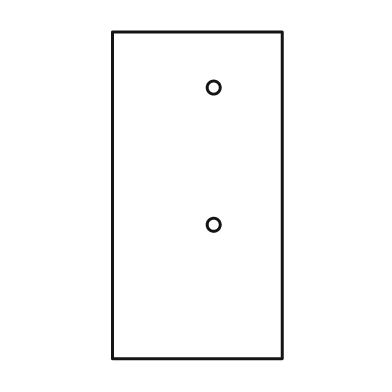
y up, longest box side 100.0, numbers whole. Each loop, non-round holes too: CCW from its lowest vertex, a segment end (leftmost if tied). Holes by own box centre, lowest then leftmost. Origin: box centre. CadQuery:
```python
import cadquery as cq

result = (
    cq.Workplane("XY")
    .moveTo(-26.0, -50.0)
    .lineTo(26.0, -50.0)
    .lineTo(26.0, 50.0)
    .lineTo(-26.0, 50.0)
    .close()
    .moveTo(5.0, -9.0)
    .circle(2.0)
    .moveTo(5.0, 33.0)
    .circle(2.0)
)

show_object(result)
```